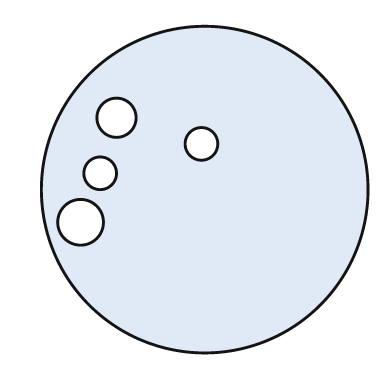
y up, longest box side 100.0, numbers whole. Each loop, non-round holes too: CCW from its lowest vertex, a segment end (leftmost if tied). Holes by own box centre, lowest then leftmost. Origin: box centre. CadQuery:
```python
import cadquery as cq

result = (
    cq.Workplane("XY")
    .moveTo(0.0, 0.0)
    .circle(50.0)
    .moveTo(-38.0, -10.0)
    .circle(7.0)
    .moveTo(-32.0, 5.0)
    .circle(5.0)
    .moveTo(-1.0, 14.0)
    .circle(5.0)
    .moveTo(-27.0, 22.0)
    .circle(6.0)
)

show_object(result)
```